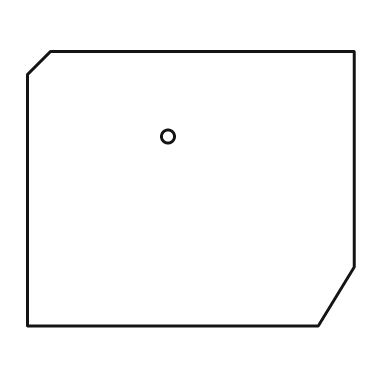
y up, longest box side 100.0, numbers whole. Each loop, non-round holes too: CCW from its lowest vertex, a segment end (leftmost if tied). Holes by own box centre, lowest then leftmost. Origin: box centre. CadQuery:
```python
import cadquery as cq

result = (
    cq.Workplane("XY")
    .moveTo(-50.0, -42.0)
    .lineTo(39.0, -42.0)
    .lineTo(50.0, -24.0)
    .lineTo(50.0, 42.0)
    .lineTo(-43.0, 42.0)
    .lineTo(-50.0, 35.0)
    .close()
    .moveTo(-7.0, 16.0)
    .circle(2.0)
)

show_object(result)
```